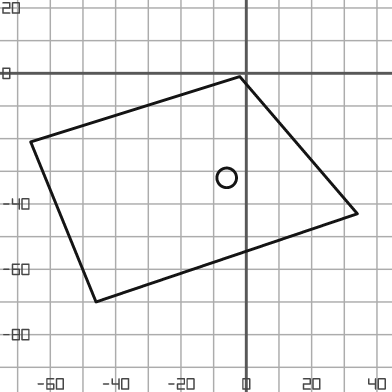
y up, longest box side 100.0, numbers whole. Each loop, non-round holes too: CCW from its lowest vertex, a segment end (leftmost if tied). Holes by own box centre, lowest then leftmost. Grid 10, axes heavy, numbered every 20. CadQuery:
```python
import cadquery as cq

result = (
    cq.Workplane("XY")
    .moveTo(-46.0, -70.0)
    .lineTo(34.0, -43.0)
    .lineTo(-2.0, -1.0)
    .lineTo(-66.0, -21.0)
    .close()
    .moveTo(-6.0, -32.0)
    .circle(3.0)
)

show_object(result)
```